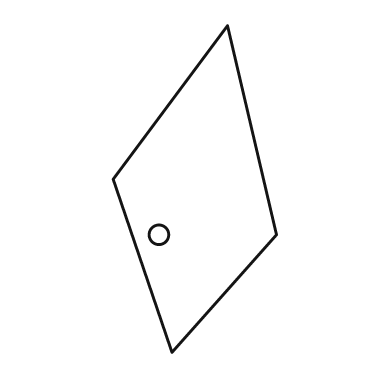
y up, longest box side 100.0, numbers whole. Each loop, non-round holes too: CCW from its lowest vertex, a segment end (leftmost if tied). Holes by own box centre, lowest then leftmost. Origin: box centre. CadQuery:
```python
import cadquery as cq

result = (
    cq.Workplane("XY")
    .moveTo(-7.0, -50.0)
    .lineTo(25.0, -14.0)
    .lineTo(10.0, 50.0)
    .lineTo(-25.0, 3.0)
    .close()
    .moveTo(-11.0, -14.0)
    .circle(3.0)
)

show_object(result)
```